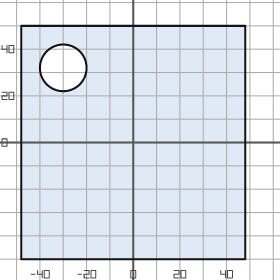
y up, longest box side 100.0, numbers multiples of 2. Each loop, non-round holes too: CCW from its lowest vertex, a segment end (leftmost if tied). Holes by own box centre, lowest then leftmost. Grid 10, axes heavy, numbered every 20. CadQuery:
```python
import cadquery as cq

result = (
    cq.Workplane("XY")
    .moveTo(-48.0, -50.0)
    .lineTo(48.0, -50.0)
    .lineTo(48.0, 50.0)
    .lineTo(-48.0, 50.0)
    .close()
    .moveTo(-30.0, 32.0)
    .circle(10.0)
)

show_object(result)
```